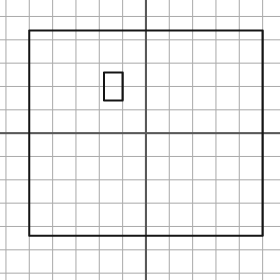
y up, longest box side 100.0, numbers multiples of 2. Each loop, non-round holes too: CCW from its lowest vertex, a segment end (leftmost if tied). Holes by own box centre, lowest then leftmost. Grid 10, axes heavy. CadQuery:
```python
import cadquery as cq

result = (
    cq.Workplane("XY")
    .moveTo(-50.0, -44.0)
    .lineTo(50.0, -44.0)
    .lineTo(50.0, 44.0)
    .lineTo(-50.0, 44.0)
    .close()
    .moveTo(-18.0, 14.0)
    .lineTo(-10.0, 14.0)
    .lineTo(-10.0, 26.0)
    .lineTo(-18.0, 26.0)
    .close()
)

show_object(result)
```